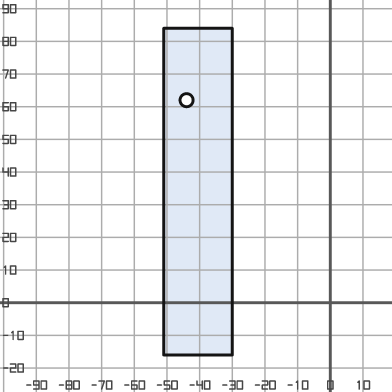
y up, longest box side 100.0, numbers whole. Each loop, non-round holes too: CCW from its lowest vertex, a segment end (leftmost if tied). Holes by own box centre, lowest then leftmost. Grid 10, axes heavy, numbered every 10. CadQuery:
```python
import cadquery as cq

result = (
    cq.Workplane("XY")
    .moveTo(-51.0, -16.0)
    .lineTo(-30.0, -16.0)
    .lineTo(-30.0, 84.0)
    .lineTo(-51.0, 84.0)
    .close()
    .moveTo(-44.0, 62.0)
    .circle(2.0)
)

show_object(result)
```